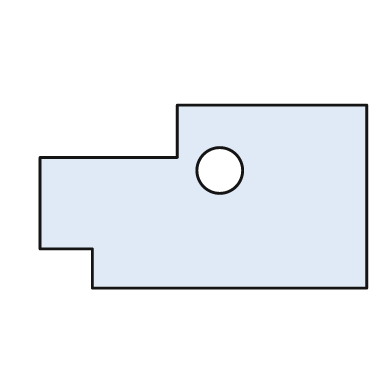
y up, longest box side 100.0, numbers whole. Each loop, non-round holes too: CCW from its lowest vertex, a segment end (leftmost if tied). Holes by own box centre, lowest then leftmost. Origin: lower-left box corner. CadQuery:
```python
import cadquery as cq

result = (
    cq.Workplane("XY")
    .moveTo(16.0, 0.0)
    .lineTo(100.0, 0.0)
    .lineTo(100.0, 56.0)
    .lineTo(42.0, 56.0)
    .lineTo(42.0, 40.0)
    .lineTo(0.0, 40.0)
    .lineTo(0.0, 12.0)
    .lineTo(16.0, 12.0)
    .close()
    .moveTo(55.0, 36.0)
    .circle(7.0)
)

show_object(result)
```